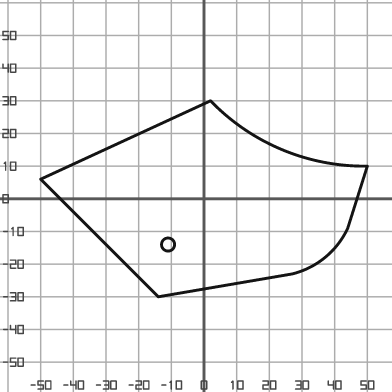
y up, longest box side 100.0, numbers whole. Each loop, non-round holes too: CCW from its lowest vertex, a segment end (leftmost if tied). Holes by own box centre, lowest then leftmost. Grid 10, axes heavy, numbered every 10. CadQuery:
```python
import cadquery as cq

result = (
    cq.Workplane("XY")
    .moveTo(-14.0, -30.0)
    .lineTo(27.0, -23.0)
    .threePointArc((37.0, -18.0), (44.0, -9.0))
    .lineTo(50.0, 10.0)
    .threePointArc((24.0, 15.0), (2.0, 30.0))
    .lineTo(-50.0, 6.0)
    .close()
    .moveTo(-11.0, -14.0)
    .circle(2.0)
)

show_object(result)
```